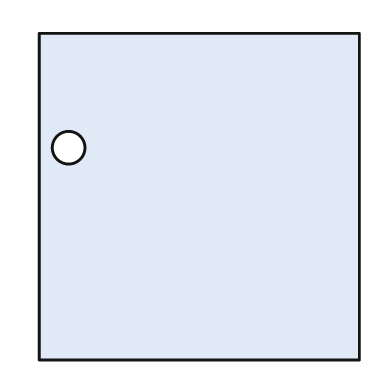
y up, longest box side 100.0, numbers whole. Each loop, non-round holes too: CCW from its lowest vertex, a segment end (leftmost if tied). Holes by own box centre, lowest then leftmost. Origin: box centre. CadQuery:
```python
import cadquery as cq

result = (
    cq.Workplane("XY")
    .moveTo(-49.0, -50.0)
    .lineTo(49.0, -50.0)
    .lineTo(49.0, 50.0)
    .lineTo(-49.0, 50.0)
    .close()
    .moveTo(-40.0, 15.0)
    .circle(5.0)
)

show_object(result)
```